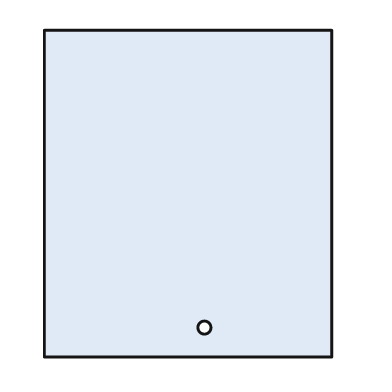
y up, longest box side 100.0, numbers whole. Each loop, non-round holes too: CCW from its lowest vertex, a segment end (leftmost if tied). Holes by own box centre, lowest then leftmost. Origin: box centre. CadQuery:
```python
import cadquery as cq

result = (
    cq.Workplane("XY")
    .moveTo(-44.0, -50.0)
    .lineTo(44.0, -50.0)
    .lineTo(44.0, 50.0)
    .lineTo(-44.0, 50.0)
    .close()
    .moveTo(5.0, -41.0)
    .circle(2.0)
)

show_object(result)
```